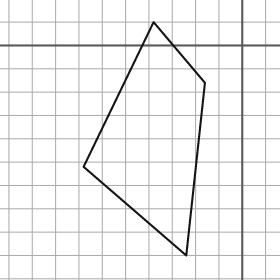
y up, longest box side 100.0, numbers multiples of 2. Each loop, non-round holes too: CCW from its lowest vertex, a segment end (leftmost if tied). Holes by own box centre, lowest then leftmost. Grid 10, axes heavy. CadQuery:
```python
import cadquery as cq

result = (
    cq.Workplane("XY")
    .moveTo(-24.0, -90.0)
    .lineTo(-16.0, -16.0)
    .lineTo(-38.0, 10.0)
    .lineTo(-68.0, -52.0)
    .close()
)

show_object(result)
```